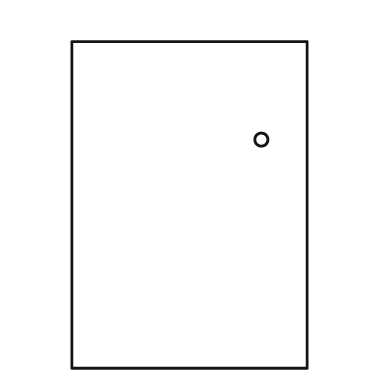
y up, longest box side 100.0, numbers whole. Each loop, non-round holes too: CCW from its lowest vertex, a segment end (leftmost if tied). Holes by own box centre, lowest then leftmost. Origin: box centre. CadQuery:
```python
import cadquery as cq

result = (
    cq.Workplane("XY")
    .moveTo(-36.0, -50.0)
    .lineTo(36.0, -50.0)
    .lineTo(36.0, 50.0)
    .lineTo(-36.0, 50.0)
    .close()
    .moveTo(22.0, 20.0)
    .circle(2.0)
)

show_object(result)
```